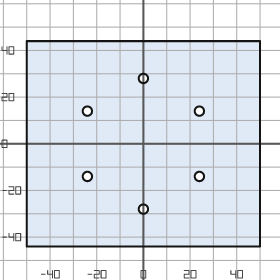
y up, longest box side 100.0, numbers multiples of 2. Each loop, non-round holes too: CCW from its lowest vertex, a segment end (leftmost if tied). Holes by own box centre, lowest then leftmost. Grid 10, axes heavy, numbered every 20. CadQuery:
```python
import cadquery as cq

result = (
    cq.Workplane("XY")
    .moveTo(-50.0, -44.0)
    .lineTo(50.0, -44.0)
    .lineTo(50.0, 44.0)
    .lineTo(-50.0, 44.0)
    .close()
    .moveTo(0.0, -28.0)
    .circle(2.0)
    .moveTo(-24.0, -14.0)
    .circle(2.0)
    .moveTo(24.0, -14.0)
    .circle(2.0)
    .moveTo(-24.0, 14.0)
    .circle(2.0)
    .moveTo(24.0, 14.0)
    .circle(2.0)
    .moveTo(0.0, 28.0)
    .circle(2.0)
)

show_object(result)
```